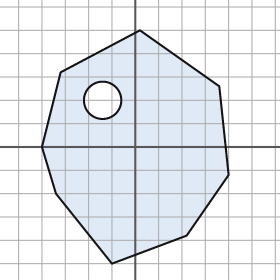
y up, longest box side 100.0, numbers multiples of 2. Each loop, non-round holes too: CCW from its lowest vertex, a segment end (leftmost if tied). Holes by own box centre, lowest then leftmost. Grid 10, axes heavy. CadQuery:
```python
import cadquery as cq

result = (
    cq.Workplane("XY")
    .moveTo(-10.0, -50.0)
    .lineTo(22.0, -38.0)
    .lineTo(40.0, -12.0)
    .lineTo(36.0, 26.0)
    .lineTo(2.0, 50.0)
    .lineTo(-32.0, 32.0)
    .lineTo(-40.0, 0.0)
    .lineTo(-34.0, -20.0)
    .close()
    .moveTo(-14.0, 20.0)
    .circle(8.0)
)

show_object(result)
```